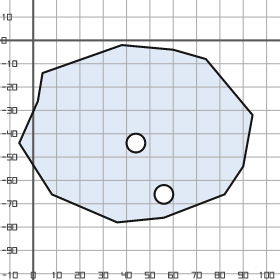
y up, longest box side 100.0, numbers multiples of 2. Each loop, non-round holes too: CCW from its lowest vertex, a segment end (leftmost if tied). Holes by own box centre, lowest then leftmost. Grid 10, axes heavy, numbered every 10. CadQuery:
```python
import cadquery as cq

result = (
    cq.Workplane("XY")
    .moveTo(36.0, -78.0)
    .lineTo(56.0, -76.0)
    .lineTo(82.0, -66.0)
    .lineTo(90.0, -54.0)
    .lineTo(94.0, -32.0)
    .lineTo(74.0, -8.0)
    .lineTo(60.0, -4.0)
    .lineTo(38.0, -2.0)
    .lineTo(4.0, -14.0)
    .lineTo(2.0, -26.0)
    .lineTo(-6.0, -44.0)
    .lineTo(8.0, -66.0)
    .close()
    .moveTo(56.0, -66.0)
    .circle(4.0)
    .moveTo(44.0, -44.0)
    .circle(4.0)
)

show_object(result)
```